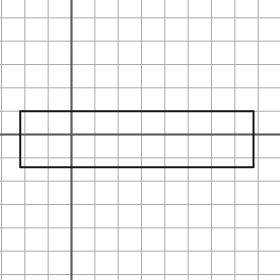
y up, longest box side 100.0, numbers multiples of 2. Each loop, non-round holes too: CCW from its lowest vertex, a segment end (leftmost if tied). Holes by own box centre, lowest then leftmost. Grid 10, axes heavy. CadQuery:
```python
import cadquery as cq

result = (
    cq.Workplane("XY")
    .moveTo(-22.0, -14.0)
    .lineTo(78.0, -14.0)
    .lineTo(78.0, 10.0)
    .lineTo(-22.0, 10.0)
    .close()
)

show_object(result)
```